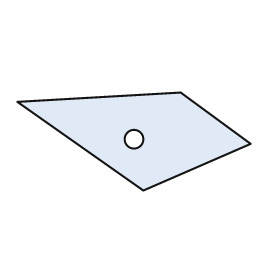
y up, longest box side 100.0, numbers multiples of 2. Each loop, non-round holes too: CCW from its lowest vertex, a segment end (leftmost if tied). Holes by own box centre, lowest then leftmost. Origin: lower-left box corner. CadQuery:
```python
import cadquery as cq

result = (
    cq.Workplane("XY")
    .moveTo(54.0, 0.0)
    .lineTo(100.0, 20.0)
    .lineTo(70.0, 42.0)
    .lineTo(0.0, 38.0)
    .close()
    .moveTo(50.0, 22.0)
    .circle(4.0)
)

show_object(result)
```